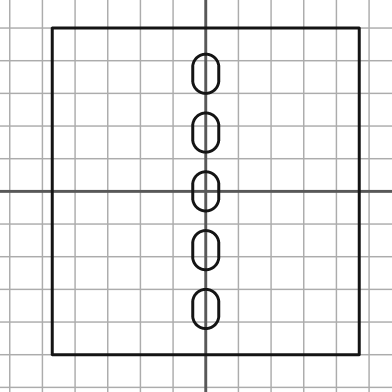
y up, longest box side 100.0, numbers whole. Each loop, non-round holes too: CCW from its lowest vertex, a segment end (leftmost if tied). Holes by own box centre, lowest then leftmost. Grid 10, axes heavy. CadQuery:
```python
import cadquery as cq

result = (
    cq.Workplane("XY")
    .moveTo(-47.0, -50.0)
    .lineTo(47.0, -50.0)
    .lineTo(47.0, 50.0)
    .lineTo(-47.0, 50.0)
    .close()
    .moveTo(-4.0, -38.0)
    .threePointArc((0.0, -42.0), (4.0, -38.0))
    .lineTo(4.0, -34.0)
    .threePointArc((0.0, -30.0), (-4.0, -34.0))
    .close()
    .moveTo(-4.0, -20.0)
    .threePointArc((0.0, -24.0), (4.0, -20.0))
    .lineTo(4.0, -16.0)
    .threePointArc((0.0, -12.0), (-4.0, -16.0))
    .close()
    .moveTo(-4.0, -2.0)
    .threePointArc((0.0, -6.0), (4.0, -2.0))
    .lineTo(4.0, 2.0)
    .threePointArc((0.0, 6.0), (-4.0, 2.0))
    .close()
    .moveTo(-4.0, 16.0)
    .threePointArc((0.0, 12.0), (4.0, 16.0))
    .lineTo(4.0, 20.0)
    .threePointArc((0.0, 24.0), (-4.0, 20.0))
    .close()
    .moveTo(-4.0, 34.0)
    .threePointArc((0.0, 30.0), (4.0, 34.0))
    .lineTo(4.0, 38.0)
    .threePointArc((0.0, 42.0), (-4.0, 38.0))
    .close()
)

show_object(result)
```